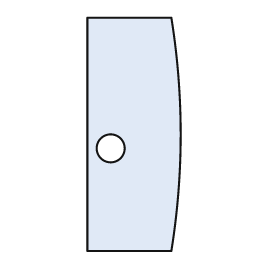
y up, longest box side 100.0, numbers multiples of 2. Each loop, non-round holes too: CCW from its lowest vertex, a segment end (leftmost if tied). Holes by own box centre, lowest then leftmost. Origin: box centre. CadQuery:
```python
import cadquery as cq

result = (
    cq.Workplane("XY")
    .moveTo(-20.0, -50.0)
    .lineTo(16.0, -50.0)
    .threePointArc((20.0, 0.0), (16.0, 50.0))
    .lineTo(-20.0, 50.0)
    .close()
    .moveTo(-10.0, -6.0)
    .circle(6.0)
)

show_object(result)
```